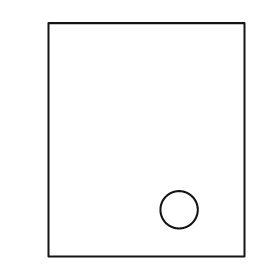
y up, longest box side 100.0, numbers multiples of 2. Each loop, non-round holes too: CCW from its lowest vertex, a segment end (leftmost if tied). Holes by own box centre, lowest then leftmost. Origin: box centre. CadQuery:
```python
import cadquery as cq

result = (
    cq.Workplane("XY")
    .moveTo(-42.0, -50.0)
    .lineTo(42.0, -50.0)
    .lineTo(42.0, 50.0)
    .lineTo(-42.0, 50.0)
    .close()
    .moveTo(14.0, -30.0)
    .circle(8.0)
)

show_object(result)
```